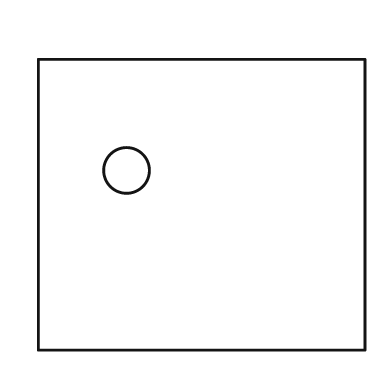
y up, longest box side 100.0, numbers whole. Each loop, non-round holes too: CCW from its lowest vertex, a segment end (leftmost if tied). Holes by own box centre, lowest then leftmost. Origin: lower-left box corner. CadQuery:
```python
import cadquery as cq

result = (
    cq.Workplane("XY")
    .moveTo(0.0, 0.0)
    .lineTo(100.0, 0.0)
    .lineTo(100.0, 89.0)
    .lineTo(0.0, 89.0)
    .close()
    .moveTo(27.0, 55.0)
    .circle(7.0)
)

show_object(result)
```